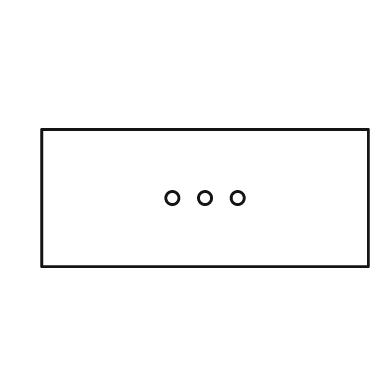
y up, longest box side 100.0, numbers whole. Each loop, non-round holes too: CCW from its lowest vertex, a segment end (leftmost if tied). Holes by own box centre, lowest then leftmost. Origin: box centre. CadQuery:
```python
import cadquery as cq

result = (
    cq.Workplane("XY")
    .moveTo(-50.0, -21.0)
    .lineTo(50.0, -21.0)
    .lineTo(50.0, 21.0)
    .lineTo(-50.0, 21.0)
    .close()
    .moveTo(-10.0, 0.0)
    .circle(2.0)
    .moveTo(0.0, 0.0)
    .circle(2.0)
    .moveTo(10.0, 0.0)
    .circle(2.0)
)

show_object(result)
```